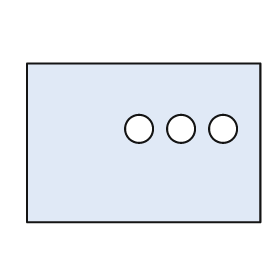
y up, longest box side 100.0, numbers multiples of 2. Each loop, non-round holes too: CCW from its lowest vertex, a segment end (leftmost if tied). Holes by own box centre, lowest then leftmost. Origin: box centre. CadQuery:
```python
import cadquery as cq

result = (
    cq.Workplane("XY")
    .moveTo(-50.0, -34.0)
    .lineTo(50.0, -34.0)
    .lineTo(50.0, 34.0)
    .lineTo(-50.0, 34.0)
    .close()
    .moveTo(-2.0, 6.0)
    .circle(6.0)
    .moveTo(16.0, 6.0)
    .circle(6.0)
    .moveTo(34.0, 6.0)
    .circle(6.0)
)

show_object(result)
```